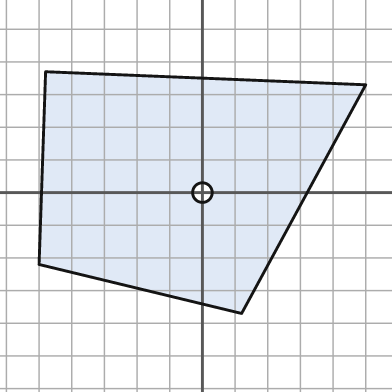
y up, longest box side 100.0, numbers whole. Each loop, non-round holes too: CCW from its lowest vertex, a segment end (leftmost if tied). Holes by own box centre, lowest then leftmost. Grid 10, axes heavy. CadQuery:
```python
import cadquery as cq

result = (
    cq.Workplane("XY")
    .moveTo(12.0, -37.0)
    .lineTo(50.0, 33.0)
    .lineTo(-48.0, 37.0)
    .lineTo(-50.0, -22.0)
    .close()
    .moveTo(0.0, 0.0)
    .circle(3.0)
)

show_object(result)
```